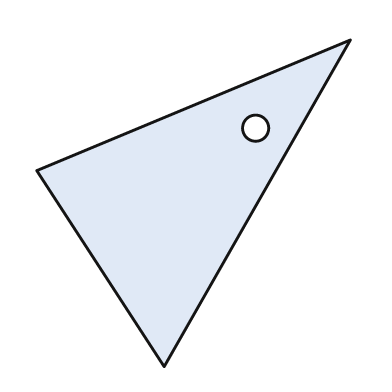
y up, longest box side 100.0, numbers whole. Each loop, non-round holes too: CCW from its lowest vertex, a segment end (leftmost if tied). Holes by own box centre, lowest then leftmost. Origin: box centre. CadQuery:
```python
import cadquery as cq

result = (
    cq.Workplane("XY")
    .moveTo(-9.0, -50.0)
    .lineTo(48.0, 50.0)
    .lineTo(-48.0, 10.0)
    .close()
    .moveTo(19.0, 23.0)
    .circle(4.0)
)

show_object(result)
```